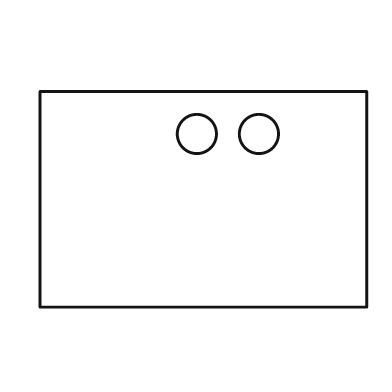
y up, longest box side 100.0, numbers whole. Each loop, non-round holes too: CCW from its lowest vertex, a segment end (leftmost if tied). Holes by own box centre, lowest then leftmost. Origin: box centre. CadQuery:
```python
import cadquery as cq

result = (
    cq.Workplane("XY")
    .moveTo(-50.0, -33.0)
    .lineTo(50.0, -33.0)
    .lineTo(50.0, 33.0)
    .lineTo(-50.0, 33.0)
    .close()
    .moveTo(-2.0, 20.0)
    .circle(6.0)
    .moveTo(17.0, 20.0)
    .circle(6.0)
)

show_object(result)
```